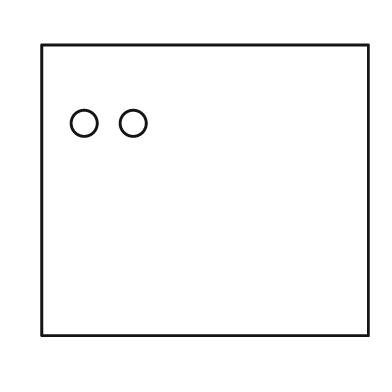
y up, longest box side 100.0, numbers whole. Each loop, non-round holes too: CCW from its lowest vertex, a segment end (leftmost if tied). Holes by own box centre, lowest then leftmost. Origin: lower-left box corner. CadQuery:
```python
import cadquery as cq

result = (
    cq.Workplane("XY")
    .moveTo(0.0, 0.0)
    .lineTo(100.0, 0.0)
    .lineTo(100.0, 89.0)
    .lineTo(0.0, 89.0)
    .close()
    .moveTo(13.0, 65.0)
    .circle(4.0)
    .moveTo(28.0, 65.0)
    .circle(4.0)
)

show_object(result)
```